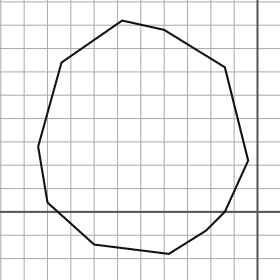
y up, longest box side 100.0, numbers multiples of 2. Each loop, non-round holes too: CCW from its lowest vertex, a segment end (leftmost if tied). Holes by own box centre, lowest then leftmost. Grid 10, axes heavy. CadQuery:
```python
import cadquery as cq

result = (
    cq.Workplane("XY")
    .moveTo(-38.0, -18.0)
    .lineTo(-22.0, -8.0)
    .lineTo(-14.0, 0.0)
    .lineTo(-4.0, 22.0)
    .lineTo(-14.0, 62.0)
    .lineTo(-40.0, 78.0)
    .lineTo(-58.0, 82.0)
    .lineTo(-84.0, 64.0)
    .lineTo(-94.0, 28.0)
    .lineTo(-90.0, 4.0)
    .lineTo(-70.0, -14.0)
    .close()
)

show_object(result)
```